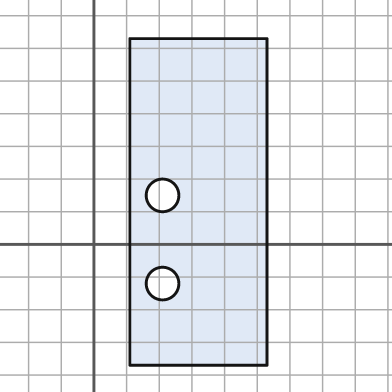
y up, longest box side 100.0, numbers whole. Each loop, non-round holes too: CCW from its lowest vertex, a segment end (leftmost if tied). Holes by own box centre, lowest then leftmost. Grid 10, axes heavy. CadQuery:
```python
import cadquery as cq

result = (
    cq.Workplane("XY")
    .moveTo(11.0, -37.0)
    .lineTo(53.0, -37.0)
    .lineTo(53.0, 63.0)
    .lineTo(11.0, 63.0)
    .close()
    .moveTo(21.0, -12.0)
    .circle(5.0)
    .moveTo(21.0, 15.0)
    .circle(5.0)
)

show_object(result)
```